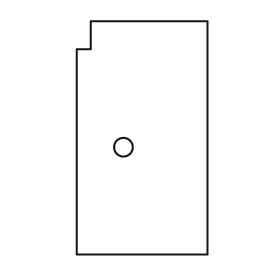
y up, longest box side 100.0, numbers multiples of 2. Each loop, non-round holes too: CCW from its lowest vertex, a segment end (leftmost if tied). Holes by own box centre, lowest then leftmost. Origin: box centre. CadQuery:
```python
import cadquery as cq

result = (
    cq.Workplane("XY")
    .moveTo(-28.0, -50.0)
    .lineTo(28.0, -50.0)
    .lineTo(28.0, 50.0)
    .lineTo(-22.0, 50.0)
    .lineTo(-22.0, 38.0)
    .lineTo(-28.0, 38.0)
    .close()
    .moveTo(-8.0, -4.0)
    .circle(4.0)
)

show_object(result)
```